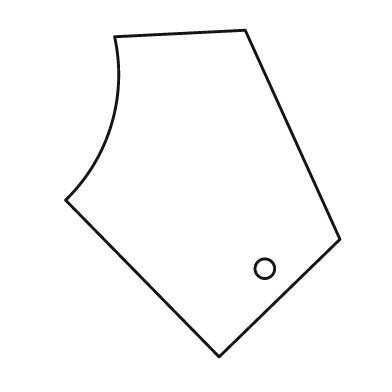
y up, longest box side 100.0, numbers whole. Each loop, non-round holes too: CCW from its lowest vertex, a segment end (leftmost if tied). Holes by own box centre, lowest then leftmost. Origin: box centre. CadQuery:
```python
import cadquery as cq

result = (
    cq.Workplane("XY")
    .moveTo(5.0, -50.0)
    .lineTo(42.0, -14.0)
    .lineTo(13.0, 50.0)
    .lineTo(-27.0, 48.0)
    .threePointArc((-28.0, 21.0), (-42.0, -2.0))
    .close()
    .moveTo(19.0, -23.0)
    .circle(3.0)
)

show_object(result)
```